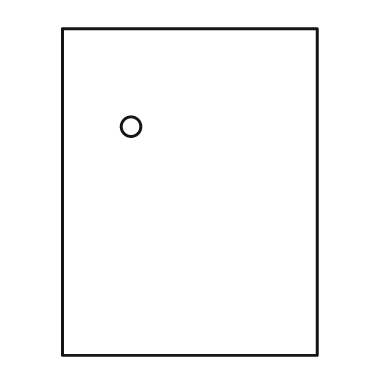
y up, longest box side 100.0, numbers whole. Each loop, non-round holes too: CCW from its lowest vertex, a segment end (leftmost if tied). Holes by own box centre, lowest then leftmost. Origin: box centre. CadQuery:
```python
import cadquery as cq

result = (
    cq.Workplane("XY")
    .moveTo(-39.0, -50.0)
    .lineTo(39.0, -50.0)
    .lineTo(39.0, 50.0)
    .lineTo(-39.0, 50.0)
    .close()
    .moveTo(-18.0, 20.0)
    .circle(3.0)
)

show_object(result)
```